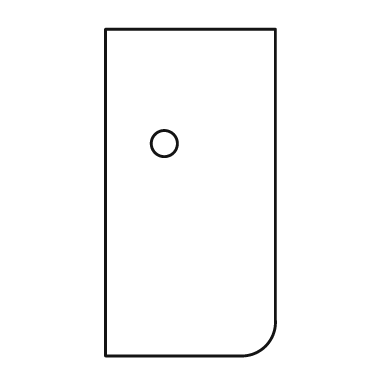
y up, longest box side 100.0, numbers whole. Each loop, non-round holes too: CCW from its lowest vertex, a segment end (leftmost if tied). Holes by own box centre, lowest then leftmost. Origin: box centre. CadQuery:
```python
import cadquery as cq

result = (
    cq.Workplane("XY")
    .moveTo(-26.0, -50.0)
    .lineTo(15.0, -50.0)
    .threePointArc((23.0, -47.0), (26.0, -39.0))
    .lineTo(26.0, 50.0)
    .lineTo(-26.0, 50.0)
    .close()
    .moveTo(-8.0, 15.0)
    .circle(4.0)
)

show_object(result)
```